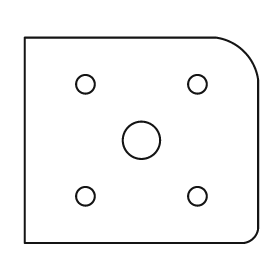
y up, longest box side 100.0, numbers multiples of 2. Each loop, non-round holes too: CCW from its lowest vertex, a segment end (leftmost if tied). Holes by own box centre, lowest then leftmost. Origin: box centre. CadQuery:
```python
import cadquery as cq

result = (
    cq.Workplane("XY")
    .moveTo(-50.0, -44.0)
    .lineTo(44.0, -44.0)
    .threePointArc((48.0, -42.0), (50.0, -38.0))
    .lineTo(50.0, 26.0)
    .threePointArc((44.0, 38.0), (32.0, 44.0))
    .lineTo(-50.0, 44.0)
    .close()
    .moveTo(-24.0, -24.0)
    .circle(4.0)
    .moveTo(24.0, -24.0)
    .circle(4.0)
    .moveTo(0.0, 0.0)
    .circle(8.0)
    .moveTo(-24.0, 24.0)
    .circle(4.0)
    .moveTo(24.0, 24.0)
    .circle(4.0)
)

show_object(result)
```